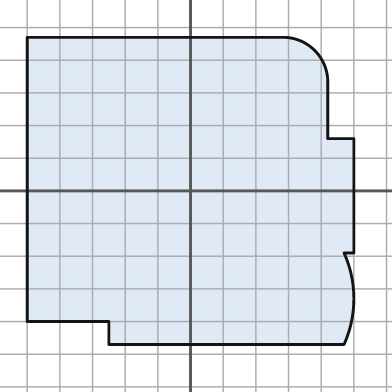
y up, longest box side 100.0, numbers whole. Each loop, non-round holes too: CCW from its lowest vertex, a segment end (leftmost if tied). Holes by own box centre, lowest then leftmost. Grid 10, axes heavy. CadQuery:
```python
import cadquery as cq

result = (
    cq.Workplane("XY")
    .moveTo(-25.0, -47.0)
    .lineTo(47.0, -47.0)
    .threePointArc((50.0, -33.0), (47.0, -19.0))
    .lineTo(50.0, -19.0)
    .lineTo(50.0, 16.0)
    .lineTo(42.0, 16.0)
    .lineTo(42.0, 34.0)
    .threePointArc((38.0, 43.0), (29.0, 47.0))
    .lineTo(-50.0, 47.0)
    .lineTo(-50.0, -40.0)
    .lineTo(-25.0, -40.0)
    .close()
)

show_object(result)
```